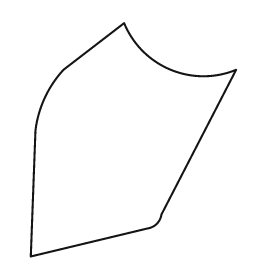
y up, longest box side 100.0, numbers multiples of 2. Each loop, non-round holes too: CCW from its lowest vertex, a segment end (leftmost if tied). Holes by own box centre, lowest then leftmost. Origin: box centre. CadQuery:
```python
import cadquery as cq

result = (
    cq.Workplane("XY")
    .moveTo(-44.0, -50.0)
    .lineTo(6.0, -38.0)
    .threePointArc((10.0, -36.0), (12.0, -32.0))
    .lineTo(44.0, 30.0)
    .threePointArc((16.0, 30.0), (-4.0, 50.0))
    .lineTo(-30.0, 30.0)
    .threePointArc((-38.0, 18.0), (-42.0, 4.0))
    .close()
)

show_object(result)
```